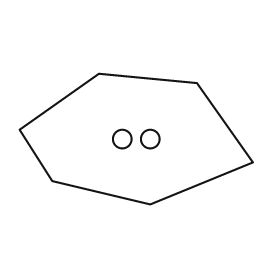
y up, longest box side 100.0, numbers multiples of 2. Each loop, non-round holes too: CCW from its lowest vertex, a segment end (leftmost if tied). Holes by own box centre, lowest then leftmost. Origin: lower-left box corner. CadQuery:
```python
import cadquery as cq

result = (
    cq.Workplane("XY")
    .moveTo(56.0, 0.0)
    .lineTo(100.0, 18.0)
    .lineTo(76.0, 52.0)
    .lineTo(34.0, 56.0)
    .lineTo(0.0, 32.0)
    .lineTo(14.0, 10.0)
    .close()
    .moveTo(44.0, 28.0)
    .circle(4.0)
    .moveTo(56.0, 28.0)
    .circle(4.0)
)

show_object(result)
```